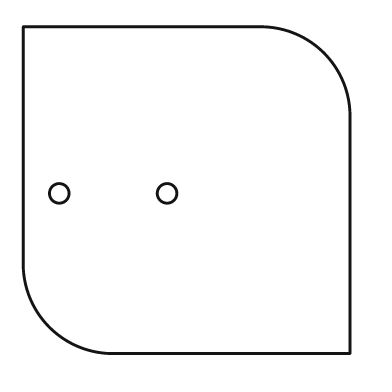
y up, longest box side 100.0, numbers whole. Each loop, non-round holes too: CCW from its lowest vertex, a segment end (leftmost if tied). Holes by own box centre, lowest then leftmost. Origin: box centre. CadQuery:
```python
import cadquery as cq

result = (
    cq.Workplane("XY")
    .moveTo(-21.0, -50.0)
    .lineTo(50.0, -50.0)
    .lineTo(50.0, 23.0)
    .threePointArc((42.0, 42.0), (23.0, 50.0))
    .lineTo(-50.0, 50.0)
    .lineTo(-50.0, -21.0)
    .threePointArc((-42.0, -42.0), (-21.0, -50.0))
    .close()
    .moveTo(-39.0, -1.0)
    .circle(3.0)
    .moveTo(-6.0, -1.0)
    .circle(3.0)
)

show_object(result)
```